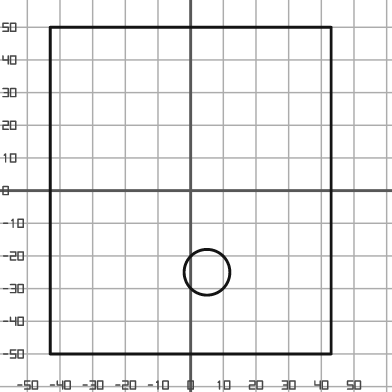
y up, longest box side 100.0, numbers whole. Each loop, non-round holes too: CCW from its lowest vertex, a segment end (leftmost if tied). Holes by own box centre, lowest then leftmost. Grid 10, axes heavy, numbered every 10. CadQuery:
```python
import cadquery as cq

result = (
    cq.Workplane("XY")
    .moveTo(-43.0, -50.0)
    .lineTo(43.0, -50.0)
    .lineTo(43.0, 50.0)
    .lineTo(-43.0, 50.0)
    .close()
    .moveTo(5.0, -25.0)
    .circle(7.0)
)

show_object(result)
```